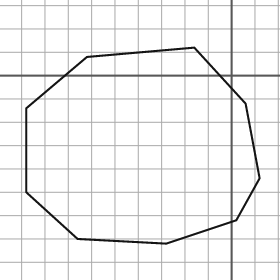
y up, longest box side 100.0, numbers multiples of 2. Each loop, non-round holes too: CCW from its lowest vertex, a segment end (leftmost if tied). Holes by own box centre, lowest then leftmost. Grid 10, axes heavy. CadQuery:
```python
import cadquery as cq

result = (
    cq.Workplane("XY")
    .moveTo(-28.0, -72.0)
    .lineTo(2.0, -62.0)
    .lineTo(12.0, -44.0)
    .lineTo(6.0, -12.0)
    .lineTo(-16.0, 12.0)
    .lineTo(-62.0, 8.0)
    .lineTo(-88.0, -14.0)
    .lineTo(-88.0, -50.0)
    .lineTo(-66.0, -70.0)
    .close()
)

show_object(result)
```